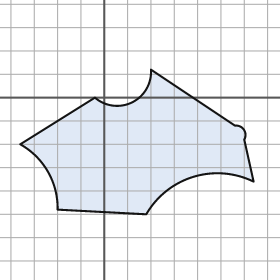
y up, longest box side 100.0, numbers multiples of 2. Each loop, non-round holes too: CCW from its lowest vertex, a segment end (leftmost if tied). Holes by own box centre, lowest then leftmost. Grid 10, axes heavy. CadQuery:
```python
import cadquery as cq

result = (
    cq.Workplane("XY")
    .moveTo(18.0, -50.0)
    .threePointArc((38.0, -34.0), (64.0, -36.0))
    .lineTo(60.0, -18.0)
    .threePointArc((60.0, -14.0), (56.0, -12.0))
    .lineTo(20.0, 12.0)
    .threePointArc((12.0, -2.0), (-4.0, 0.0))
    .lineTo(-36.0, -20.0)
    .threePointArc((-24.0, -32.0), (-20.0, -48.0))
    .close()
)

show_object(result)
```